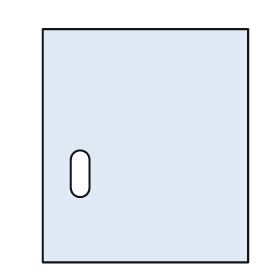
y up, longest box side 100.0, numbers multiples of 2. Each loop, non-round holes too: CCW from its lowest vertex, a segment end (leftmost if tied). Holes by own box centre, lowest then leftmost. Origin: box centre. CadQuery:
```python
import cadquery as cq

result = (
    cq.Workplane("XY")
    .moveTo(-44.0, -50.0)
    .lineTo(44.0, -50.0)
    .lineTo(44.0, 50.0)
    .lineTo(-44.0, 50.0)
    .close()
    .moveTo(-32.0, -18.0)
    .threePointArc((-28.0, -22.0), (-24.0, -18.0))
    .lineTo(-24.0, -6.0)
    .threePointArc((-28.0, -2.0), (-32.0, -6.0))
    .close()
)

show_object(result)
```